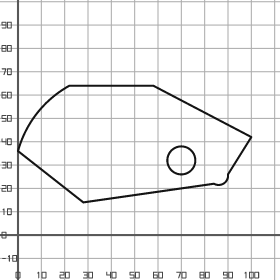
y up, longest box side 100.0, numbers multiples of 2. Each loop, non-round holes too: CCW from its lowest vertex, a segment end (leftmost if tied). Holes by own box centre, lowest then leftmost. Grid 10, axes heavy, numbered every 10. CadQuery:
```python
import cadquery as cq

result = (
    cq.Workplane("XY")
    .moveTo(28.0, 14.0)
    .lineTo(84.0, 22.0)
    .threePointArc((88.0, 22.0), (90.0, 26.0))
    .lineTo(100.0, 42.0)
    .lineTo(58.0, 64.0)
    .lineTo(22.0, 64.0)
    .threePointArc((8.0, 52.0), (0.0, 36.0))
    .close()
    .moveTo(70.0, 32.0)
    .circle(6.0)
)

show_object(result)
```